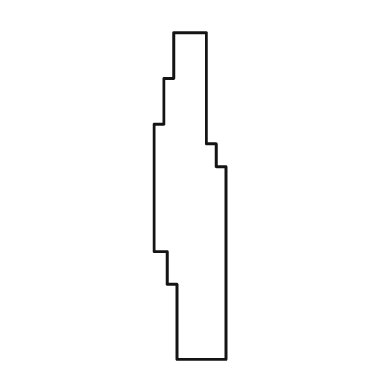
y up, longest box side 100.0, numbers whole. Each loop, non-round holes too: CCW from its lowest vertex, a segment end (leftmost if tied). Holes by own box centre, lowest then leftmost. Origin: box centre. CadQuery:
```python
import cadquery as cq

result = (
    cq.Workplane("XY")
    .moveTo(-4.0, -50.0)
    .lineTo(11.0, -50.0)
    .lineTo(11.0, 9.0)
    .lineTo(8.0, 9.0)
    .lineTo(8.0, 16.0)
    .lineTo(5.0, 16.0)
    .lineTo(5.0, 50.0)
    .lineTo(-5.0, 50.0)
    .lineTo(-5.0, 36.0)
    .lineTo(-8.0, 36.0)
    .lineTo(-8.0, 22.0)
    .lineTo(-11.0, 22.0)
    .lineTo(-11.0, -17.0)
    .lineTo(-7.0, -17.0)
    .lineTo(-7.0, -27.0)
    .lineTo(-4.0, -27.0)
    .close()
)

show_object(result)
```